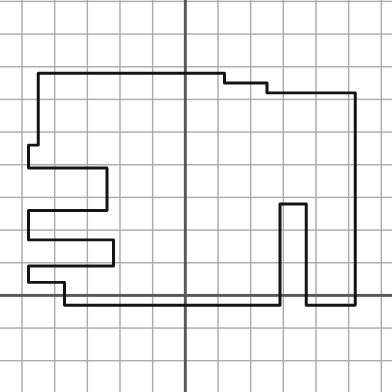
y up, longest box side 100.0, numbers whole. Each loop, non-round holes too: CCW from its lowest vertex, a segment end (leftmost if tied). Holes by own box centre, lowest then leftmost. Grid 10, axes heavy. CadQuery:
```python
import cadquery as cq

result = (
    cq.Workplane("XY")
    .moveTo(-37.0, -3.0)
    .lineTo(29.0, -3.0)
    .lineTo(29.0, 28.0)
    .lineTo(37.0, 28.0)
    .lineTo(37.0, -3.0)
    .lineTo(52.0, -3.0)
    .lineTo(52.0, 62.0)
    .lineTo(25.0, 62.0)
    .lineTo(25.0, 65.0)
    .lineTo(12.0, 65.0)
    .lineTo(12.0, 68.0)
    .lineTo(-45.0, 68.0)
    .lineTo(-45.0, 46.0)
    .lineTo(-48.0, 46.0)
    .lineTo(-48.0, 39.0)
    .lineTo(-24.0, 39.0)
    .lineTo(-24.0, 26.0)
    .lineTo(-48.0, 26.0)
    .lineTo(-48.0, 17.0)
    .lineTo(-22.0, 17.0)
    .lineTo(-22.0, 9.0)
    .lineTo(-48.0, 9.0)
    .lineTo(-48.0, 4.0)
    .lineTo(-37.0, 4.0)
    .close()
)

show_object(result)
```